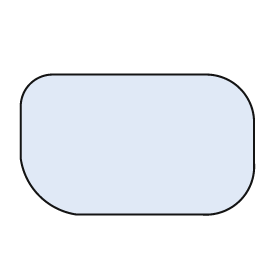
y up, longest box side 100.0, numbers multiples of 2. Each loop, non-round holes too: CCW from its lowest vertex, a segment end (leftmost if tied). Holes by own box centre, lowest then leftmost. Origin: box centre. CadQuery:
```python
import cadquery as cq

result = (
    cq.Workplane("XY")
    .moveTo(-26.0, -30.0)
    .lineTo(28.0, -30.0)
    .threePointArc((44.0, -24.0), (50.0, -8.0))
    .lineTo(50.0, 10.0)
    .threePointArc((44.0, 24.0), (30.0, 30.0))
    .lineTo(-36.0, 30.0)
    .threePointArc((-46.0, 26.0), (-50.0, 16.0))
    .lineTo(-50.0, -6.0)
    .threePointArc((-42.0, -22.0), (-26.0, -30.0))
    .close()
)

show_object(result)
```